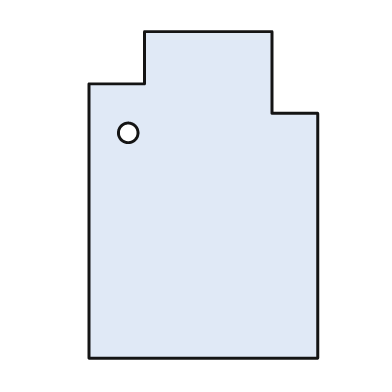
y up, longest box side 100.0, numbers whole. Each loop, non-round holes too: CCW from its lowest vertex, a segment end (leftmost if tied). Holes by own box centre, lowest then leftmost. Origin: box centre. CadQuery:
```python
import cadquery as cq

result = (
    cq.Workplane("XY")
    .moveTo(-35.0, -50.0)
    .lineTo(35.0, -50.0)
    .lineTo(35.0, 25.0)
    .lineTo(21.0, 25.0)
    .lineTo(21.0, 50.0)
    .lineTo(-18.0, 50.0)
    .lineTo(-18.0, 34.0)
    .lineTo(-35.0, 34.0)
    .close()
    .moveTo(-23.0, 19.0)
    .circle(3.0)
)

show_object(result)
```